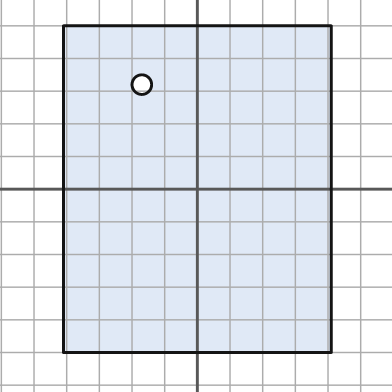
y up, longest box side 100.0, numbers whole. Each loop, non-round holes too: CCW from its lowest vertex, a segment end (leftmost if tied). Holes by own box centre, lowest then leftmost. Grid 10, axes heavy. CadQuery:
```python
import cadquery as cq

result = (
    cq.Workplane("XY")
    .moveTo(-41.0, -50.0)
    .lineTo(41.0, -50.0)
    .lineTo(41.0, 50.0)
    .lineTo(-41.0, 50.0)
    .close()
    .moveTo(-17.0, 32.0)
    .circle(3.0)
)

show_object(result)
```